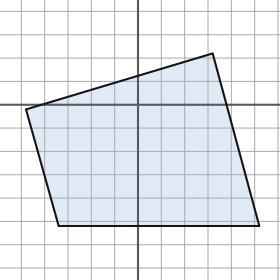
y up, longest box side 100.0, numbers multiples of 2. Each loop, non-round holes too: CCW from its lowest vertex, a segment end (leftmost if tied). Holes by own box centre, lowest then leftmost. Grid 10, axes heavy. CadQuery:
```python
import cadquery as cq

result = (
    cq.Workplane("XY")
    .moveTo(-34.0, -52.0)
    .lineTo(52.0, -52.0)
    .lineTo(32.0, 22.0)
    .lineTo(-48.0, -2.0)
    .close()
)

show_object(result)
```